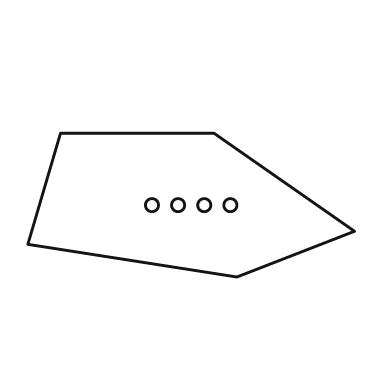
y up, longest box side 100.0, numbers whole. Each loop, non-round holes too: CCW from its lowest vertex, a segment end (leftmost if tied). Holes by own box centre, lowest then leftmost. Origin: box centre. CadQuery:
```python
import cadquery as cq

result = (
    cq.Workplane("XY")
    .moveTo(14.0, -22.0)
    .lineTo(50.0, -8.0)
    .lineTo(7.0, 22.0)
    .lineTo(-40.0, 22.0)
    .lineTo(-50.0, -12.0)
    .close()
    .moveTo(-12.0, 0.0)
    .circle(2.0)
    .moveTo(-4.0, 0.0)
    .circle(2.0)
    .moveTo(4.0, 0.0)
    .circle(2.0)
    .moveTo(12.0, 0.0)
    .circle(2.0)
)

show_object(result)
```